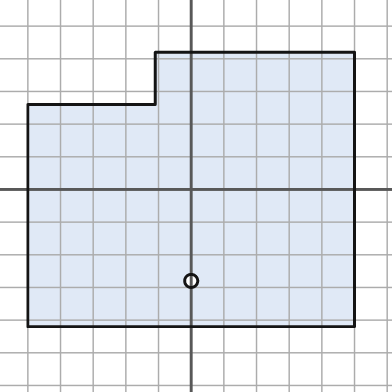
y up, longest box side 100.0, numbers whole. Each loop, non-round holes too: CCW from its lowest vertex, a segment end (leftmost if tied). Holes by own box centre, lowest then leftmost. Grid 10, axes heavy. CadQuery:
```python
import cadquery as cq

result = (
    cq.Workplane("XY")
    .moveTo(-50.0, -42.0)
    .lineTo(50.0, -42.0)
    .lineTo(50.0, 42.0)
    .lineTo(-11.0, 42.0)
    .lineTo(-11.0, 26.0)
    .lineTo(-50.0, 26.0)
    .close()
    .moveTo(0.0, -28.0)
    .circle(2.0)
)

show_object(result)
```